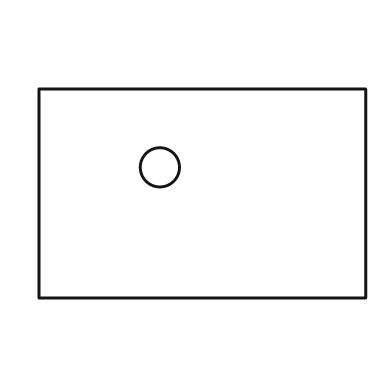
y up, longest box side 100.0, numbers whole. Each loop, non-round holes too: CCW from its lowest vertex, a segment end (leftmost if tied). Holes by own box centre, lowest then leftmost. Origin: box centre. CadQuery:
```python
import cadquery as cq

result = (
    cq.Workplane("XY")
    .moveTo(-50.0, -32.0)
    .lineTo(50.0, -32.0)
    .lineTo(50.0, 32.0)
    .lineTo(-50.0, 32.0)
    .close()
    .moveTo(-13.0, 8.0)
    .circle(6.0)
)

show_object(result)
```